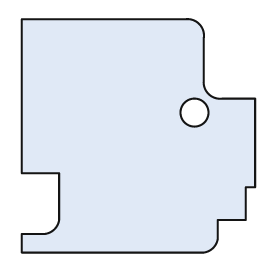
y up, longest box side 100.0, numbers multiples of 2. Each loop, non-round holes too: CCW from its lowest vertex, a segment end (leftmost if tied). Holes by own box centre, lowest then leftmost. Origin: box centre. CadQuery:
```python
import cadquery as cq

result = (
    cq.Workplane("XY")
    .moveTo(-50.0, -50.0)
    .lineTo(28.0, -50.0)
    .threePointArc((32.0, -48.0), (34.0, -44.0))
    .lineTo(34.0, -36.0)
    .lineTo(46.0, -36.0)
    .lineTo(46.0, -22.0)
    .lineTo(50.0, -22.0)
    .lineTo(50.0, 16.0)
    .lineTo(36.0, 16.0)
    .threePointArc((30.0, 18.0), (28.0, 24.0))
    .lineTo(28.0, 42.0)
    .threePointArc((26.0, 48.0), (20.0, 50.0))
    .lineTo(-50.0, 50.0)
    .lineTo(-50.0, -16.0)
    .lineTo(-34.0, -16.0)
    .lineTo(-34.0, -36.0)
    .threePointArc((-36.0, -40.0), (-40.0, -42.0))
    .lineTo(-50.0, -42.0)
    .close()
    .moveTo(24.0, 10.0)
    .circle(6.0)
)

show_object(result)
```